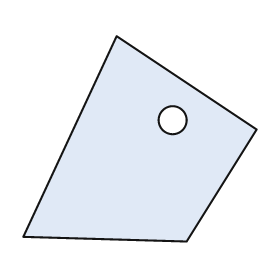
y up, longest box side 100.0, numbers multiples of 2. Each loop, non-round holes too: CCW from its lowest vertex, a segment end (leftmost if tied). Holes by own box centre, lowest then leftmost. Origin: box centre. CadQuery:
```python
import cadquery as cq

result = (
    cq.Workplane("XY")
    .moveTo(20.0, -44.0)
    .lineTo(50.0, 4.0)
    .lineTo(-10.0, 44.0)
    .lineTo(-50.0, -42.0)
    .close()
    .moveTo(14.0, 8.0)
    .circle(6.0)
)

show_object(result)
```